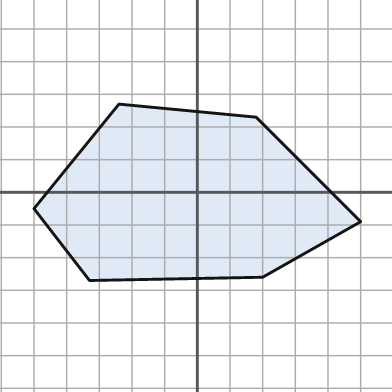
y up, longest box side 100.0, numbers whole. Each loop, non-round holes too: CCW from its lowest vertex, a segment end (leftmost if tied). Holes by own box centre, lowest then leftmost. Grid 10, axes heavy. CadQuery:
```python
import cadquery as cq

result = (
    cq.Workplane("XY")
    .moveTo(-33.0, -27.0)
    .lineTo(20.0, -26.0)
    .lineTo(50.0, -9.0)
    .lineTo(18.0, 23.0)
    .lineTo(-24.0, 27.0)
    .lineTo(-50.0, -5.0)
    .close()
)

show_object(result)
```